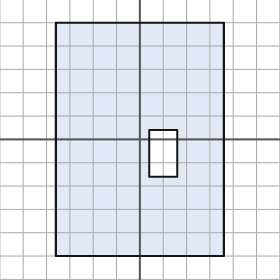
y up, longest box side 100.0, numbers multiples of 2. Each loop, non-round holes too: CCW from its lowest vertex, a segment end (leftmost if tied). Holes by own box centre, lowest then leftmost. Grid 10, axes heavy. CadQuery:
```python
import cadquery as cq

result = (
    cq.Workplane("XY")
    .moveTo(-36.0, -50.0)
    .lineTo(36.0, -50.0)
    .lineTo(36.0, 50.0)
    .lineTo(-36.0, 50.0)
    .close()
    .moveTo(4.0, -16.0)
    .lineTo(16.0, -16.0)
    .lineTo(16.0, 4.0)
    .lineTo(4.0, 4.0)
    .close()
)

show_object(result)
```